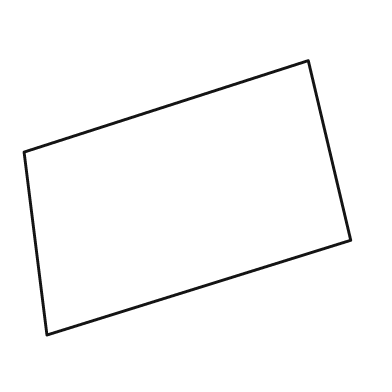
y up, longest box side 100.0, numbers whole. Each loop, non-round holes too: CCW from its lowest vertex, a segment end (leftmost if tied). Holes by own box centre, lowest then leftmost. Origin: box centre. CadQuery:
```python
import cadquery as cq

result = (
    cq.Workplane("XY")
    .moveTo(-43.0, -42.0)
    .lineTo(50.0, -13.0)
    .lineTo(37.0, 42.0)
    .lineTo(-50.0, 14.0)
    .close()
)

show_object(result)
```